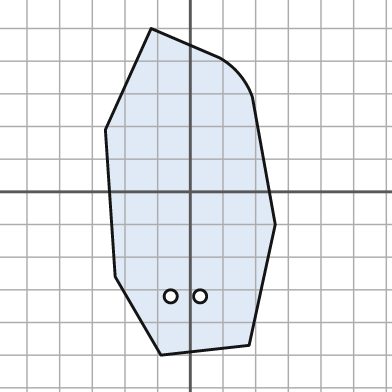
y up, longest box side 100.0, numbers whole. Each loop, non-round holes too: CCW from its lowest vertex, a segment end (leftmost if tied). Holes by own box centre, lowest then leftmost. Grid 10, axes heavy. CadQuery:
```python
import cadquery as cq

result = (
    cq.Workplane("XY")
    .moveTo(-9.0, -50.0)
    .lineTo(18.0, -47.0)
    .lineTo(26.0, -10.0)
    .lineTo(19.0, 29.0)
    .threePointArc((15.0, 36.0), (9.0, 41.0))
    .lineTo(-12.0, 50.0)
    .lineTo(-26.0, 19.0)
    .lineTo(-23.0, -26.0)
    .close()
    .moveTo(-6.0, -32.0)
    .circle(2.0)
    .moveTo(3.0, -32.0)
    .circle(2.0)
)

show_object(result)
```